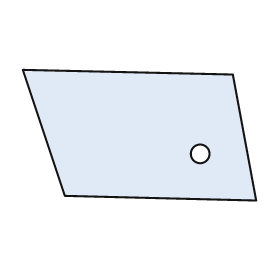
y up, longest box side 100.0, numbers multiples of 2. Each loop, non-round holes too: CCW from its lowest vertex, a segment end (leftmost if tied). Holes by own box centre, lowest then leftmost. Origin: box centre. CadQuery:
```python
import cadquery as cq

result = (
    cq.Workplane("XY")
    .moveTo(50.0, -28.0)
    .lineTo(40.0, 26.0)
    .lineTo(-50.0, 28.0)
    .lineTo(-32.0, -26.0)
    .close()
    .moveTo(26.0, -8.0)
    .circle(4.0)
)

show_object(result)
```